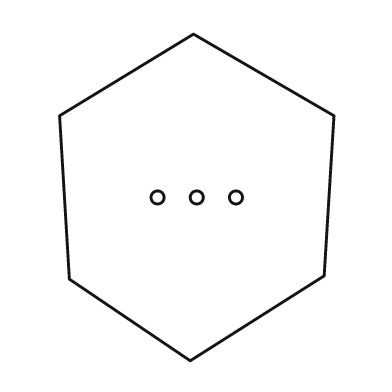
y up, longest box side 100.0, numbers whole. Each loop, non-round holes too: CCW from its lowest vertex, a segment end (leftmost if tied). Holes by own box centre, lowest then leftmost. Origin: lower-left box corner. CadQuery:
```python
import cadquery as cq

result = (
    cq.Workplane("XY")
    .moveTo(40.0, 0.0)
    .lineTo(81.0, 26.0)
    .lineTo(84.0, 75.0)
    .lineTo(41.0, 100.0)
    .lineTo(0.0, 75.0)
    .lineTo(3.0, 25.0)
    .close()
    .moveTo(30.0, 50.0)
    .circle(2.0)
    .moveTo(42.0, 50.0)
    .circle(2.0)
    .moveTo(54.0, 50.0)
    .circle(2.0)
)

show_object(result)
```